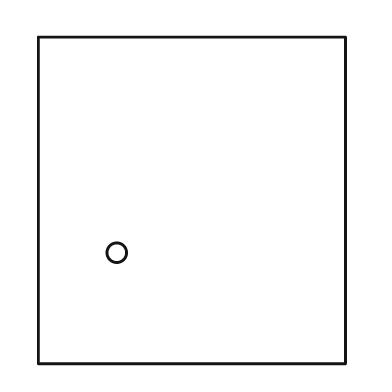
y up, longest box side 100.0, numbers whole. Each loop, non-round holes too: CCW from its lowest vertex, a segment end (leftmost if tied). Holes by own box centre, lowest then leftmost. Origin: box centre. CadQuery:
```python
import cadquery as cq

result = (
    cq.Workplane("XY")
    .moveTo(-47.0, -50.0)
    .lineTo(47.0, -50.0)
    .lineTo(47.0, 50.0)
    .lineTo(-47.0, 50.0)
    .close()
    .moveTo(-23.0, -16.0)
    .circle(3.0)
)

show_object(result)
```